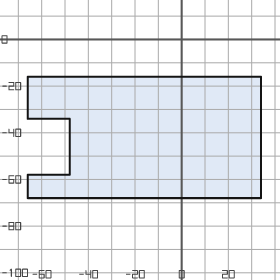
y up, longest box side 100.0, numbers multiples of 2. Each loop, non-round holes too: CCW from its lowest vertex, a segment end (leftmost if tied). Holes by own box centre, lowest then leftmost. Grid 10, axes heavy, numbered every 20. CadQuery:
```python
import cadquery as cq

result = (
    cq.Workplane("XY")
    .moveTo(-66.0, -68.0)
    .lineTo(34.0, -68.0)
    .lineTo(34.0, -16.0)
    .lineTo(-66.0, -16.0)
    .lineTo(-66.0, -34.0)
    .lineTo(-48.0, -34.0)
    .lineTo(-48.0, -58.0)
    .lineTo(-66.0, -58.0)
    .close()
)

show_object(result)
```